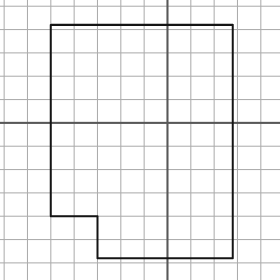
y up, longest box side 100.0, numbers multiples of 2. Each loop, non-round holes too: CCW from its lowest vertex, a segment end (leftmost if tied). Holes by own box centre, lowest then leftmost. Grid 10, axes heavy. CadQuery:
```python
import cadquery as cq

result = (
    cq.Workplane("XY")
    .moveTo(-30.0, -58.0)
    .lineTo(28.0, -58.0)
    .lineTo(28.0, 42.0)
    .lineTo(-50.0, 42.0)
    .lineTo(-50.0, -40.0)
    .lineTo(-30.0, -40.0)
    .close()
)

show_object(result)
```